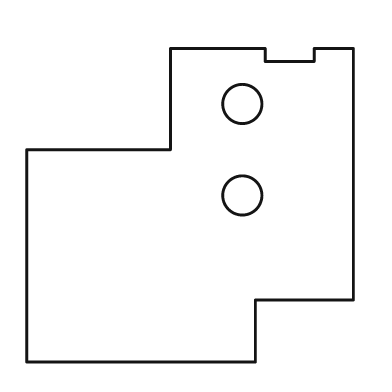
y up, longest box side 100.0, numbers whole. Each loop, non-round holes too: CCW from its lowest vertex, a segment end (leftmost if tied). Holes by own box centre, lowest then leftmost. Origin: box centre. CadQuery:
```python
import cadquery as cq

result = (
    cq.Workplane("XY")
    .moveTo(-50.0, -48.0)
    .lineTo(20.0, -48.0)
    .lineTo(20.0, -29.0)
    .lineTo(50.0, -29.0)
    .lineTo(50.0, 48.0)
    .lineTo(38.0, 48.0)
    .lineTo(38.0, 44.0)
    .lineTo(23.0, 44.0)
    .lineTo(23.0, 48.0)
    .lineTo(-6.0, 48.0)
    .lineTo(-6.0, 17.0)
    .lineTo(-50.0, 17.0)
    .close()
    .moveTo(16.0, 3.0)
    .circle(6.0)
    .moveTo(16.0, 31.0)
    .circle(6.0)
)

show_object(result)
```